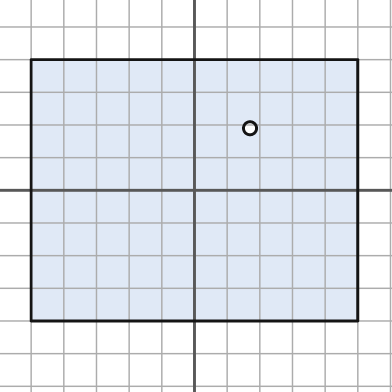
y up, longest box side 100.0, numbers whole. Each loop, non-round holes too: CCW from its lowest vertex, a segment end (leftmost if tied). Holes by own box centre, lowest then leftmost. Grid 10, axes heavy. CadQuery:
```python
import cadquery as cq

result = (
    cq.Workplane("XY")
    .moveTo(-50.0, -40.0)
    .lineTo(50.0, -40.0)
    .lineTo(50.0, 40.0)
    .lineTo(-50.0, 40.0)
    .close()
    .moveTo(17.0, 19.0)
    .circle(2.0)
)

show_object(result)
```